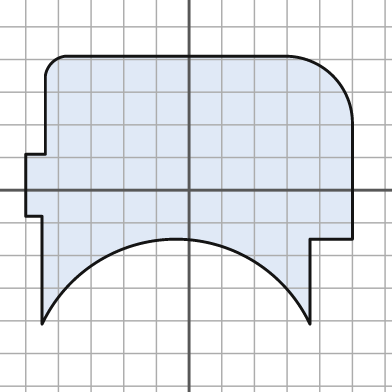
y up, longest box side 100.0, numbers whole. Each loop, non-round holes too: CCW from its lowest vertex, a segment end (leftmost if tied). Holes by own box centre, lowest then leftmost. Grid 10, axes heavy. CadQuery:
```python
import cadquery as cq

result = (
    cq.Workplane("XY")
    .moveTo(-45.0, -41.0)
    .threePointArc((-4.0, -15.0), (37.0, -41.0))
    .lineTo(37.0, -15.0)
    .lineTo(50.0, -15.0)
    .lineTo(50.0, 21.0)
    .threePointArc((44.0, 35.0), (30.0, 41.0))
    .lineTo(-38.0, 41.0)
    .threePointArc((-42.0, 39.0), (-44.0, 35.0))
    .lineTo(-44.0, 11.0)
    .lineTo(-50.0, 11.0)
    .lineTo(-50.0, -8.0)
    .lineTo(-45.0, -8.0)
    .close()
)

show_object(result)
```